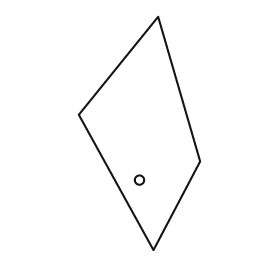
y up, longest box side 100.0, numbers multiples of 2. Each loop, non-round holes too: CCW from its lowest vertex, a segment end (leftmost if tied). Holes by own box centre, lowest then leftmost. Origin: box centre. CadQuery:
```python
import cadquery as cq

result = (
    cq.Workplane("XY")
    .moveTo(6.0, -50.0)
    .lineTo(26.0, -12.0)
    .lineTo(8.0, 50.0)
    .lineTo(-26.0, 8.0)
    .close()
    .moveTo(0.0, -20.0)
    .circle(2.0)
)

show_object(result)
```